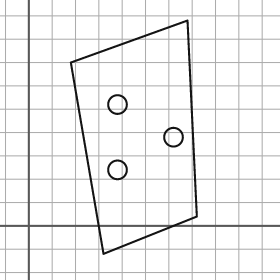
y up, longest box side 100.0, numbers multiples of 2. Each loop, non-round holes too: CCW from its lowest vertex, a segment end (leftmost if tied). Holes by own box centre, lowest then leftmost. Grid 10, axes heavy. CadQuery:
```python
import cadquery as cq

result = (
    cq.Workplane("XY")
    .moveTo(32.0, -12.0)
    .lineTo(72.0, 4.0)
    .lineTo(68.0, 88.0)
    .lineTo(18.0, 70.0)
    .close()
    .moveTo(38.0, 24.0)
    .circle(4.0)
    .moveTo(62.0, 38.0)
    .circle(4.0)
    .moveTo(38.0, 52.0)
    .circle(4.0)
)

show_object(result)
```